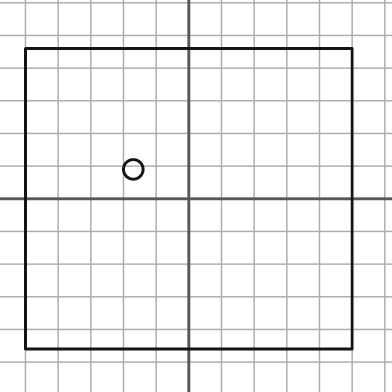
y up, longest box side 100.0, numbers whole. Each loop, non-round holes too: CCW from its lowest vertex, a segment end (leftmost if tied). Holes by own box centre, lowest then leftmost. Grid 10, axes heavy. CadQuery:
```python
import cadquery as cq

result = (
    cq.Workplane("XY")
    .moveTo(-50.0, -46.0)
    .lineTo(50.0, -46.0)
    .lineTo(50.0, 46.0)
    .lineTo(-50.0, 46.0)
    .close()
    .moveTo(-17.0, 9.0)
    .circle(3.0)
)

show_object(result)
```